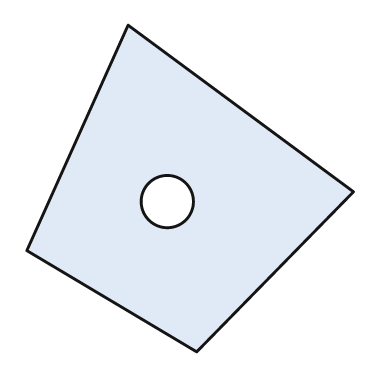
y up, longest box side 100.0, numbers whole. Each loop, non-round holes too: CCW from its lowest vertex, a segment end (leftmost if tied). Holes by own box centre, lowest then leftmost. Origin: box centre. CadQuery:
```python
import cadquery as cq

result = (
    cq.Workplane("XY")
    .moveTo(2.0, -50.0)
    .lineTo(50.0, -1.0)
    .lineTo(-19.0, 50.0)
    .lineTo(-50.0, -19.0)
    .close()
    .moveTo(-7.0, -4.0)
    .circle(8.0)
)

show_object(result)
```